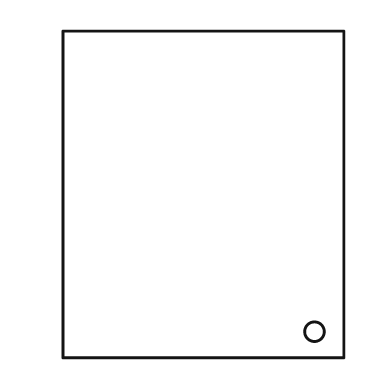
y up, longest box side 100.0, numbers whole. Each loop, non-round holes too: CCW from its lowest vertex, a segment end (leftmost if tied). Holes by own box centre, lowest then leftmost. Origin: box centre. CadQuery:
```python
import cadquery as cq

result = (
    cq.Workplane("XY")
    .moveTo(-43.0, -50.0)
    .lineTo(43.0, -50.0)
    .lineTo(43.0, 50.0)
    .lineTo(-43.0, 50.0)
    .close()
    .moveTo(34.0, -42.0)
    .circle(3.0)
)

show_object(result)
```